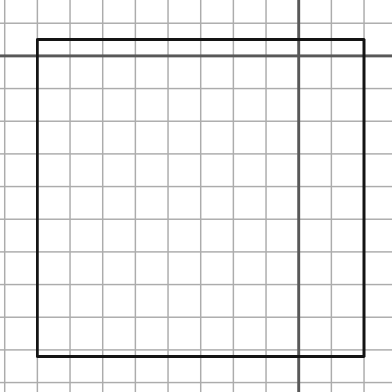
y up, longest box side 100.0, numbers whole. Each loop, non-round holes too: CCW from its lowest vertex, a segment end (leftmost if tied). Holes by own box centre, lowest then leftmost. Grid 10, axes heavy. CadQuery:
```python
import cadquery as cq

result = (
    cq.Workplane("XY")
    .moveTo(-80.0, -92.0)
    .lineTo(20.0, -92.0)
    .lineTo(20.0, 5.0)
    .lineTo(-80.0, 5.0)
    .close()
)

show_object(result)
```